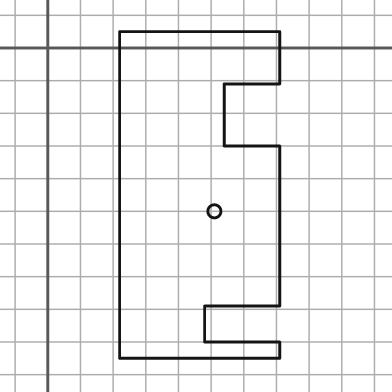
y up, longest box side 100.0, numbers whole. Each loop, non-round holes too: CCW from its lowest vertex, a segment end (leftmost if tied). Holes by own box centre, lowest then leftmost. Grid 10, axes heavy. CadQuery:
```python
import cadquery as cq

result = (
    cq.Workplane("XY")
    .moveTo(22.0, -95.0)
    .lineTo(71.0, -95.0)
    .lineTo(71.0, -90.0)
    .lineTo(48.0, -90.0)
    .lineTo(48.0, -79.0)
    .lineTo(71.0, -79.0)
    .lineTo(71.0, -30.0)
    .lineTo(54.0, -30.0)
    .lineTo(54.0, -11.0)
    .lineTo(71.0, -11.0)
    .lineTo(71.0, 5.0)
    .lineTo(22.0, 5.0)
    .close()
    .moveTo(51.0, -50.0)
    .circle(2.0)
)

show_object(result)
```